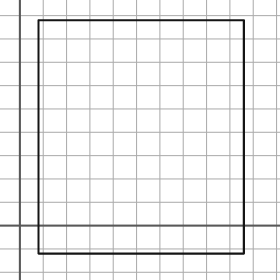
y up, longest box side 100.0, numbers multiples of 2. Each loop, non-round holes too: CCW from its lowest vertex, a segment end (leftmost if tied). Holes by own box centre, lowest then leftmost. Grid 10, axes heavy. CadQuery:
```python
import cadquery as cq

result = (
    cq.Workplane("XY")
    .moveTo(8.0, -12.0)
    .lineTo(96.0, -12.0)
    .lineTo(96.0, 88.0)
    .lineTo(8.0, 88.0)
    .close()
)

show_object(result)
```